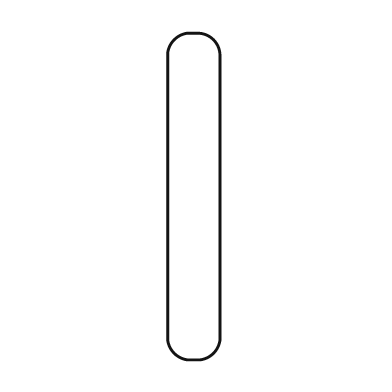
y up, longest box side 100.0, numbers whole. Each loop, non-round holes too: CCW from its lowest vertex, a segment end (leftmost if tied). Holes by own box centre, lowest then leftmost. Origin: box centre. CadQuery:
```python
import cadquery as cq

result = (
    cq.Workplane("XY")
    .moveTo(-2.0, -50.0)
    .lineTo(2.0, -50.0)
    .threePointArc((6.0, -48.0), (8.0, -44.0))
    .lineTo(8.0, 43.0)
    .threePointArc((6.0, 48.0), (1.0, 50.0))
    .lineTo(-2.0, 50.0)
    .threePointArc((-6.0, 48.0), (-8.0, 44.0))
    .lineTo(-8.0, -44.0)
    .threePointArc((-6.0, -48.0), (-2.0, -50.0))
    .close()
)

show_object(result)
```